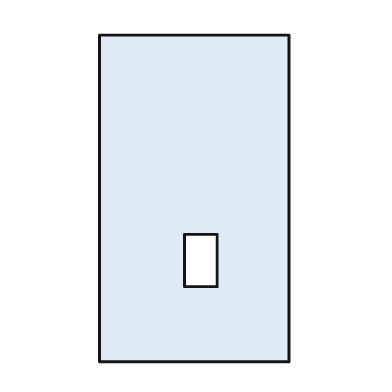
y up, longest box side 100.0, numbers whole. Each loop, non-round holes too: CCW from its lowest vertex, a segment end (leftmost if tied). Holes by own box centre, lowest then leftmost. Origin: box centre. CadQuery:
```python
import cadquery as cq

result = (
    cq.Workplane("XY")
    .moveTo(-29.0, -50.0)
    .lineTo(29.0, -50.0)
    .lineTo(29.0, 50.0)
    .lineTo(-29.0, 50.0)
    .close()
    .moveTo(-3.0, -27.0)
    .lineTo(7.0, -27.0)
    .lineTo(7.0, -11.0)
    .lineTo(-3.0, -11.0)
    .close()
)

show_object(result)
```